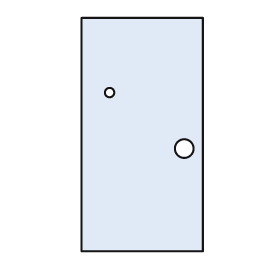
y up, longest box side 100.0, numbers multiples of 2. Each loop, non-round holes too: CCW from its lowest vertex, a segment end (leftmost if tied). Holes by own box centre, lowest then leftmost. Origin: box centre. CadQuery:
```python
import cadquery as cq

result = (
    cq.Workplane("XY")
    .moveTo(-26.0, -50.0)
    .lineTo(26.0, -50.0)
    .lineTo(26.0, 50.0)
    .lineTo(-26.0, 50.0)
    .close()
    .moveTo(18.0, -6.0)
    .circle(4.0)
    .moveTo(-14.0, 18.0)
    .circle(2.0)
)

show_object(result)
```